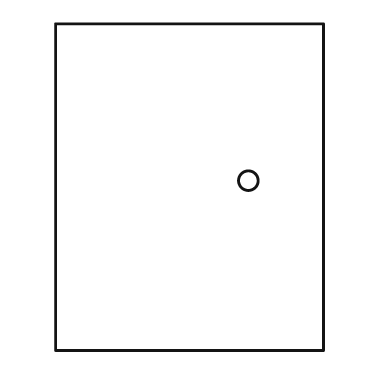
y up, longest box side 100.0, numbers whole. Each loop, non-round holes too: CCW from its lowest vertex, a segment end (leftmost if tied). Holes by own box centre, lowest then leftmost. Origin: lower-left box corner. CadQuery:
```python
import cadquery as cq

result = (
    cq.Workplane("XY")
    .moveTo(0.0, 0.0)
    .lineTo(82.0, 0.0)
    .lineTo(82.0, 100.0)
    .lineTo(0.0, 100.0)
    .close()
    .moveTo(59.0, 52.0)
    .circle(3.0)
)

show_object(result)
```